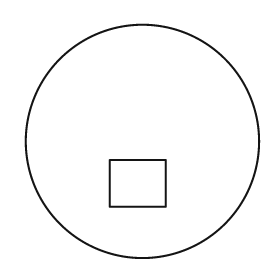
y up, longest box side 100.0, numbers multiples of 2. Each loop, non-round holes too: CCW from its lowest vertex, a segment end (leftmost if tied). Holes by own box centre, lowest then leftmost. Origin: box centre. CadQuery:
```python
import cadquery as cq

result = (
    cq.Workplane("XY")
    .moveTo(0.0, 0.0)
    .circle(50.0)
    .moveTo(-14.0, -28.0)
    .lineTo(10.0, -28.0)
    .lineTo(10.0, -8.0)
    .lineTo(-14.0, -8.0)
    .close()
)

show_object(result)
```